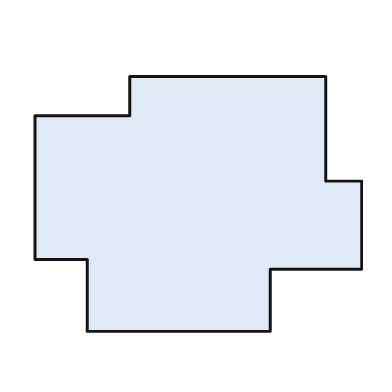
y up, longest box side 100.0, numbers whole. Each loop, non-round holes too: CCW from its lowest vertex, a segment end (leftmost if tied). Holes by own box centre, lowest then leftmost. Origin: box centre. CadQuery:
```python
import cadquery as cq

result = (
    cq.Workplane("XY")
    .moveTo(-34.0, -39.0)
    .lineTo(22.0, -39.0)
    .lineTo(22.0, -20.0)
    .lineTo(50.0, -20.0)
    .lineTo(50.0, 7.0)
    .lineTo(39.0, 7.0)
    .lineTo(39.0, 39.0)
    .lineTo(-21.0, 39.0)
    .lineTo(-21.0, 27.0)
    .lineTo(-50.0, 27.0)
    .lineTo(-50.0, -17.0)
    .lineTo(-34.0, -17.0)
    .close()
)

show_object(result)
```